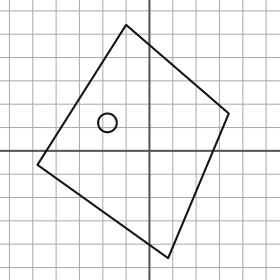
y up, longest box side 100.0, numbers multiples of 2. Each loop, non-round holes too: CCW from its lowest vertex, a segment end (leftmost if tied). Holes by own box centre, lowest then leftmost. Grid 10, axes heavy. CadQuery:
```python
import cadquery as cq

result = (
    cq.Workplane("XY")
    .moveTo(8.0, -46.0)
    .lineTo(34.0, 16.0)
    .lineTo(-10.0, 54.0)
    .lineTo(-48.0, -6.0)
    .close()
    .moveTo(-18.0, 12.0)
    .circle(4.0)
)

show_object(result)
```